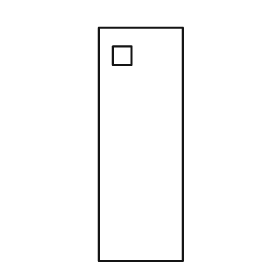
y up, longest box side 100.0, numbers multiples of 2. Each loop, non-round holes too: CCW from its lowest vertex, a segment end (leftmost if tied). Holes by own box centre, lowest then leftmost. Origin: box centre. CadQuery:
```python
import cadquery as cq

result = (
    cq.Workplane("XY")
    .moveTo(-18.0, -50.0)
    .lineTo(18.0, -50.0)
    .lineTo(18.0, 50.0)
    .lineTo(-18.0, 50.0)
    .close()
    .moveTo(-12.0, 34.0)
    .lineTo(-4.0, 34.0)
    .lineTo(-4.0, 42.0)
    .lineTo(-12.0, 42.0)
    .close()
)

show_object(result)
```